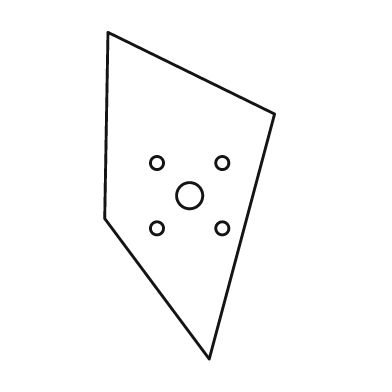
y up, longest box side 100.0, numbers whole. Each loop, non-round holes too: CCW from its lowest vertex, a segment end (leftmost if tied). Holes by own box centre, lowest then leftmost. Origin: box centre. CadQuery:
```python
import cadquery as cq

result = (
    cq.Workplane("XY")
    .moveTo(6.0, -50.0)
    .lineTo(26.0, 25.0)
    .lineTo(-25.0, 50.0)
    .lineTo(-26.0, -7.0)
    .close()
    .moveTo(-10.0, -10.0)
    .circle(2.0)
    .moveTo(10.0, -10.0)
    .circle(2.0)
    .moveTo(0.0, 0.0)
    .circle(4.0)
    .moveTo(-10.0, 10.0)
    .circle(2.0)
    .moveTo(10.0, 10.0)
    .circle(2.0)
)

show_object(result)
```